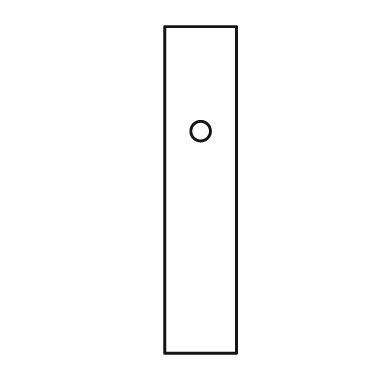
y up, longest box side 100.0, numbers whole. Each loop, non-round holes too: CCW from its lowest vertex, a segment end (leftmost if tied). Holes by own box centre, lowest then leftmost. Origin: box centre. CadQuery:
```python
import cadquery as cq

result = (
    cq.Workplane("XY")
    .moveTo(-11.0, -50.0)
    .lineTo(11.0, -50.0)
    .lineTo(11.0, 50.0)
    .lineTo(-11.0, 50.0)
    .close()
    .moveTo(0.0, 18.0)
    .circle(3.0)
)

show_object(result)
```